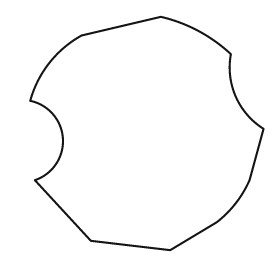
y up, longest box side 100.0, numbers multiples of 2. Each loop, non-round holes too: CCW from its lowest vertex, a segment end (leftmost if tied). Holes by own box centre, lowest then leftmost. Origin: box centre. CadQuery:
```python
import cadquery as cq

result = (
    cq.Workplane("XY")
    .moveTo(10.0, -50.0)
    .lineTo(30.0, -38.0)
    .threePointArc((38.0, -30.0), (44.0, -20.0))
    .lineTo(50.0, 2.0)
    .threePointArc((38.0, 16.0), (36.0, 34.0))
    .threePointArc((22.0, 44.0), (6.0, 50.0))
    .lineTo(-28.0, 42.0)
    .threePointArc((-42.0, 30.0), (-50.0, 14.0))
    .threePointArc((-36.0, -2.0), (-48.0, -20.0))
    .lineTo(-24.0, -46.0)
    .close()
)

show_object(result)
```